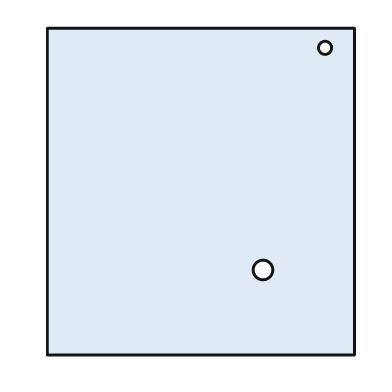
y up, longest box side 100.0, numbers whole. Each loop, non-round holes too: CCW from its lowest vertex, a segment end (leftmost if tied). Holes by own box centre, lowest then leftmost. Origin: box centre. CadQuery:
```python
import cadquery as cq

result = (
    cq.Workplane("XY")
    .moveTo(-47.0, -50.0)
    .lineTo(47.0, -50.0)
    .lineTo(47.0, 50.0)
    .lineTo(-47.0, 50.0)
    .close()
    .moveTo(19.0, -24.0)
    .circle(3.0)
    .moveTo(38.0, 44.0)
    .circle(2.0)
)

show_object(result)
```